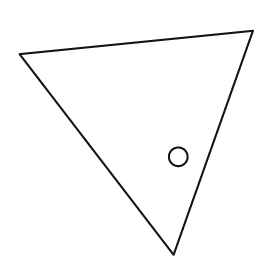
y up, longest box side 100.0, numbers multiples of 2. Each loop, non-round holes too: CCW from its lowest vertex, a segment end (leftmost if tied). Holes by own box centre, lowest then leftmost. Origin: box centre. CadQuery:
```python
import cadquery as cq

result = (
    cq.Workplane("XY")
    .moveTo(16.0, -48.0)
    .lineTo(50.0, 48.0)
    .lineTo(-50.0, 38.0)
    .close()
    .moveTo(18.0, -6.0)
    .circle(4.0)
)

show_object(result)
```